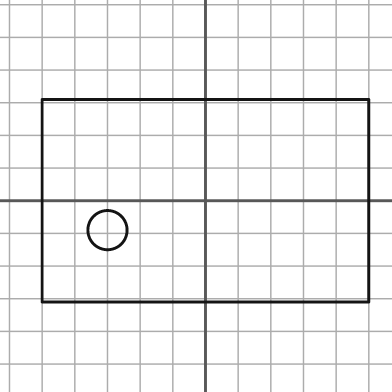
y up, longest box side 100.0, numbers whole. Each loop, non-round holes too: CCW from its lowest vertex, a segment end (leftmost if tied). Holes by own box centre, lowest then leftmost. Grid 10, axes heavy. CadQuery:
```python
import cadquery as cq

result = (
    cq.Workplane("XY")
    .moveTo(-50.0, -31.0)
    .lineTo(50.0, -31.0)
    .lineTo(50.0, 31.0)
    .lineTo(-50.0, 31.0)
    .close()
    .moveTo(-30.0, -9.0)
    .circle(6.0)
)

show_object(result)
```